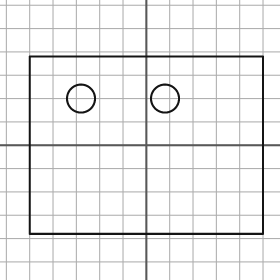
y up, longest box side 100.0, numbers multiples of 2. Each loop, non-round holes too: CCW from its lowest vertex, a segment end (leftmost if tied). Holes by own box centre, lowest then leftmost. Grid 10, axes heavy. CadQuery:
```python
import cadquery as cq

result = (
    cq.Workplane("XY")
    .moveTo(-50.0, -38.0)
    .lineTo(50.0, -38.0)
    .lineTo(50.0, 38.0)
    .lineTo(-50.0, 38.0)
    .close()
    .moveTo(-28.0, 20.0)
    .circle(6.0)
    .moveTo(8.0, 20.0)
    .circle(6.0)
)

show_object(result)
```